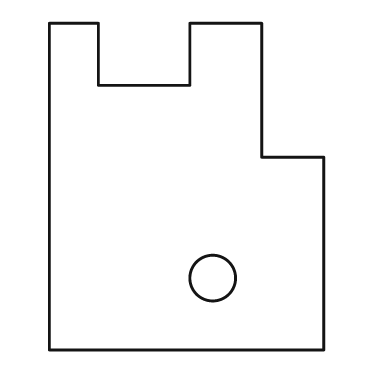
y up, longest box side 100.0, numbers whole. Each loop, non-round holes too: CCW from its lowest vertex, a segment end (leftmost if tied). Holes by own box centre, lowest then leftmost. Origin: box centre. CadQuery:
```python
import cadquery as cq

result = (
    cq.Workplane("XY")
    .moveTo(-42.0, -50.0)
    .lineTo(42.0, -50.0)
    .lineTo(42.0, 9.0)
    .lineTo(23.0, 9.0)
    .lineTo(23.0, 50.0)
    .lineTo(1.0, 50.0)
    .lineTo(1.0, 31.0)
    .lineTo(-27.0, 31.0)
    .lineTo(-27.0, 50.0)
    .lineTo(-42.0, 50.0)
    .close()
    .moveTo(8.0, -28.0)
    .circle(7.0)
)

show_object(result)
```